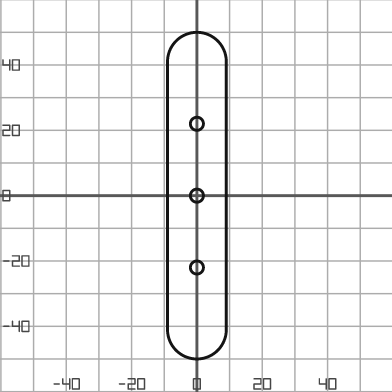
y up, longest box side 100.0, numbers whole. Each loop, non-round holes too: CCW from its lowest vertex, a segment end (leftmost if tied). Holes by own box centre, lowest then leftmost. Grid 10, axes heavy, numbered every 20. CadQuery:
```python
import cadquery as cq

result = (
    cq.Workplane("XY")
    .moveTo(-9.0, -41.0)
    .threePointArc((0.0, -50.0), (9.0, -41.0))
    .lineTo(9.0, 41.0)
    .threePointArc((0.0, 50.0), (-9.0, 41.0))
    .close()
    .moveTo(0.0, -22.0)
    .circle(2.0)
    .moveTo(0.0, 0.0)
    .circle(2.0)
    .moveTo(0.0, 22.0)
    .circle(2.0)
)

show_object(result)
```